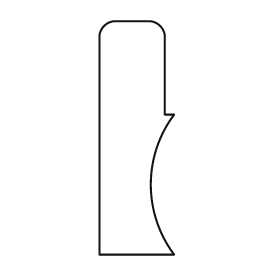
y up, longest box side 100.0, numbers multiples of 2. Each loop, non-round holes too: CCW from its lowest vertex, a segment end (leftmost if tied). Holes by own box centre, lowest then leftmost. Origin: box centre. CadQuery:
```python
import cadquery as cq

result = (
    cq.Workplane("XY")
    .moveTo(-16.0, -50.0)
    .lineTo(16.0, -50.0)
    .threePointArc((6.0, -20.0), (16.0, 10.0))
    .lineTo(12.0, 10.0)
    .lineTo(12.0, 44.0)
    .threePointArc((10.0, 48.0), (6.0, 50.0))
    .lineTo(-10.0, 50.0)
    .threePointArc((-14.0, 48.0), (-16.0, 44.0))
    .close()
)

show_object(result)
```